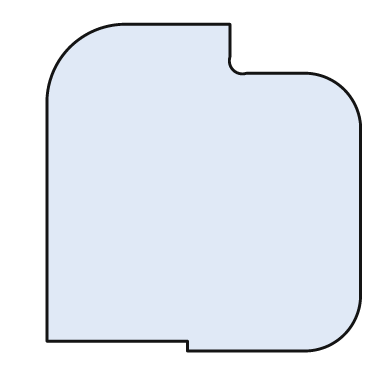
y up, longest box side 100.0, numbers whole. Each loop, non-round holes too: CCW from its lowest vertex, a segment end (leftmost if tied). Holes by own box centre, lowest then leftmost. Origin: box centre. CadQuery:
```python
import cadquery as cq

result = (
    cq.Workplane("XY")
    .moveTo(-5.0, -50.0)
    .lineTo(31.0, -50.0)
    .threePointArc((43.0, -45.0), (48.0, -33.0))
    .lineTo(48.0, 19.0)
    .threePointArc((43.0, 30.0), (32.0, 35.0))
    .lineTo(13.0, 35.0)
    .threePointArc((9.0, 36.0), (8.0, 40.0))
    .lineTo(8.0, 50.0)
    .lineTo(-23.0, 50.0)
    .threePointArc((-41.0, 43.0), (-48.0, 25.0))
    .lineTo(-48.0, -47.0)
    .lineTo(-5.0, -47.0)
    .close()
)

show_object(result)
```